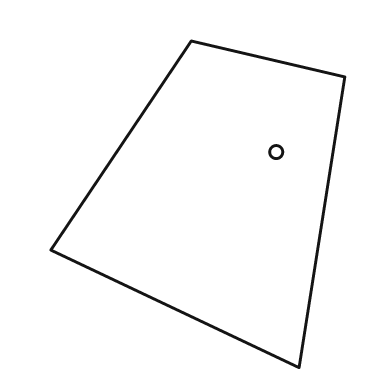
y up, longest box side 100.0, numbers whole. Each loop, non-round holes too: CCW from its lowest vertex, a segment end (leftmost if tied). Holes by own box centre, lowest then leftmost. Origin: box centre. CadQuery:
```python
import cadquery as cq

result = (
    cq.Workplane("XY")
    .moveTo(31.0, -50.0)
    .lineTo(45.0, 39.0)
    .lineTo(-2.0, 50.0)
    .lineTo(-45.0, -14.0)
    .close()
    .moveTo(24.0, 16.0)
    .circle(2.0)
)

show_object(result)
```